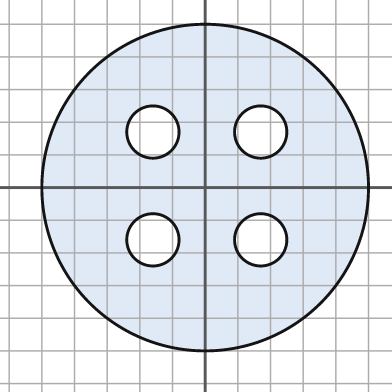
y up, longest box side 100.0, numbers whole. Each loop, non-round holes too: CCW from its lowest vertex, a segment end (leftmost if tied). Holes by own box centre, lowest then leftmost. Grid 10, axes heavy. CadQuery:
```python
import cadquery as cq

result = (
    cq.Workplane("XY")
    .moveTo(0.0, 0.0)
    .circle(50.0)
    .moveTo(-16.0, -16.0)
    .circle(8.0)
    .moveTo(17.0, -16.0)
    .circle(8.0)
    .moveTo(-16.0, 17.0)
    .circle(8.0)
    .moveTo(17.0, 17.0)
    .circle(8.0)
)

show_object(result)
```